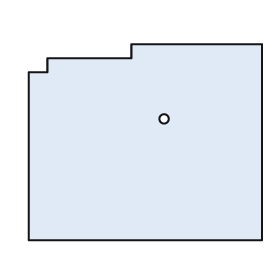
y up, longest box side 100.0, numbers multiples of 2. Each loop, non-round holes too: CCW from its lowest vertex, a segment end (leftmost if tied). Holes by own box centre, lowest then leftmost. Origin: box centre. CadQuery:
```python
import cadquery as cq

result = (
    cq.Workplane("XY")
    .moveTo(-50.0, -42.0)
    .lineTo(50.0, -42.0)
    .lineTo(50.0, 42.0)
    .lineTo(-6.0, 42.0)
    .lineTo(-6.0, 36.0)
    .lineTo(-42.0, 36.0)
    .lineTo(-42.0, 30.0)
    .lineTo(-50.0, 30.0)
    .close()
    .moveTo(8.0, 10.0)
    .circle(2.0)
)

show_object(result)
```